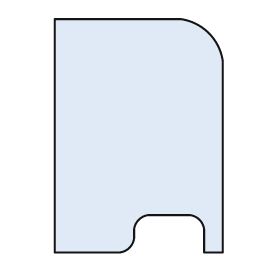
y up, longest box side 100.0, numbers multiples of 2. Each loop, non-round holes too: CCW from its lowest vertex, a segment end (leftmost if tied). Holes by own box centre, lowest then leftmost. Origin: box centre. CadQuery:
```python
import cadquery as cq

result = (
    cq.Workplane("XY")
    .moveTo(-36.0, -50.0)
    .lineTo(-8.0, -50.0)
    .threePointArc((-4.0, -48.0), (-2.0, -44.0))
    .lineTo(-2.0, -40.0)
    .threePointArc((0.0, -36.0), (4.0, -34.0))
    .lineTo(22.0, -34.0)
    .threePointArc((26.0, -36.0), (28.0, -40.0))
    .lineTo(28.0, -50.0)
    .lineTo(36.0, -50.0)
    .lineTo(36.0, 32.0)
    .threePointArc((30.0, 44.0), (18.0, 50.0))
    .lineTo(-36.0, 50.0)
    .close()
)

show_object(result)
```